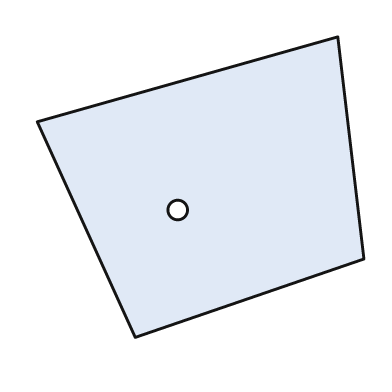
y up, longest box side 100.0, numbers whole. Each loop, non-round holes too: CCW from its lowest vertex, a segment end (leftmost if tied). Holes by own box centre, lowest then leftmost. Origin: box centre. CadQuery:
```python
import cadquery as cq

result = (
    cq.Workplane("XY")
    .moveTo(-20.0, -46.0)
    .lineTo(50.0, -22.0)
    .lineTo(42.0, 46.0)
    .lineTo(-50.0, 20.0)
    .close()
    .moveTo(-7.0, -7.0)
    .circle(3.0)
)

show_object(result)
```